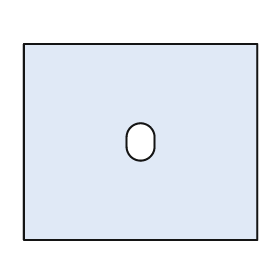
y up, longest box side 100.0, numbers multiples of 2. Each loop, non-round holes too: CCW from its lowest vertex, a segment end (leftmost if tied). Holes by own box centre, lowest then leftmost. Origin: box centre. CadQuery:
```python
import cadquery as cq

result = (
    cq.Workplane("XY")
    .moveTo(-50.0, -42.0)
    .lineTo(50.0, -42.0)
    .lineTo(50.0, 42.0)
    .lineTo(-50.0, 42.0)
    .close()
    .moveTo(-6.0, -2.0)
    .threePointArc((0.0, -8.0), (6.0, -2.0))
    .lineTo(6.0, 2.0)
    .threePointArc((0.0, 8.0), (-6.0, 2.0))
    .close()
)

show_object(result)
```